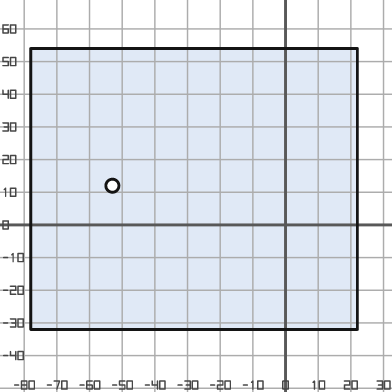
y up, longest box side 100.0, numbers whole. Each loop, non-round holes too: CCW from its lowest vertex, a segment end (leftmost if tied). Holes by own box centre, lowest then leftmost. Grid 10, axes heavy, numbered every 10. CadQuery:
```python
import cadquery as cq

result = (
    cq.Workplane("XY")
    .moveTo(-78.0, -32.0)
    .lineTo(22.0, -32.0)
    .lineTo(22.0, 54.0)
    .lineTo(-78.0, 54.0)
    .close()
    .moveTo(-53.0, 12.0)
    .circle(2.0)
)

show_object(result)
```